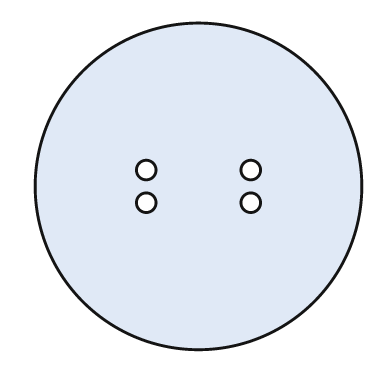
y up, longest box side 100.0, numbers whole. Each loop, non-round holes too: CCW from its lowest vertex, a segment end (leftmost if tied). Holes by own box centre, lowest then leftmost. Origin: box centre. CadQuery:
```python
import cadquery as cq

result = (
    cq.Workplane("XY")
    .moveTo(0.0, 0.0)
    .circle(50.0)
    .moveTo(-16.0, -5.0)
    .circle(3.0)
    .moveTo(16.0, -5.0)
    .circle(3.0)
    .moveTo(-16.0, 5.0)
    .circle(3.0)
    .moveTo(16.0, 5.0)
    .circle(3.0)
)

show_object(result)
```